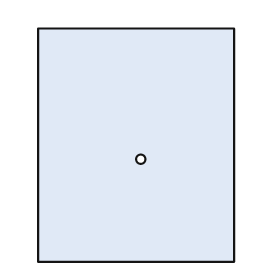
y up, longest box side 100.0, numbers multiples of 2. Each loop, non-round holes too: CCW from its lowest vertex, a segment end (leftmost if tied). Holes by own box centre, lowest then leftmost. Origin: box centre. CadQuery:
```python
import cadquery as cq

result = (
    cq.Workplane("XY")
    .moveTo(-42.0, -50.0)
    .lineTo(42.0, -50.0)
    .lineTo(42.0, 50.0)
    .lineTo(-42.0, 50.0)
    .close()
    .moveTo(2.0, -6.0)
    .circle(2.0)
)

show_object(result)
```